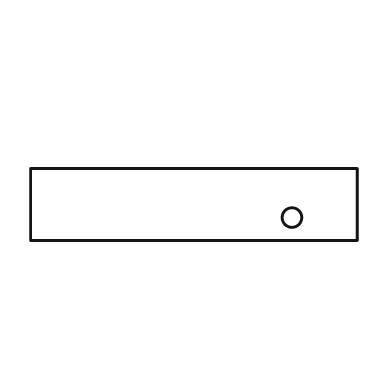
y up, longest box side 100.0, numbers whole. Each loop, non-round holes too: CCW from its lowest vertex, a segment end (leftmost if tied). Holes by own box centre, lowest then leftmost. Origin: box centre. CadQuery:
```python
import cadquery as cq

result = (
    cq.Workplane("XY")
    .moveTo(-50.0, -11.0)
    .lineTo(50.0, -11.0)
    .lineTo(50.0, 11.0)
    .lineTo(-50.0, 11.0)
    .close()
    .moveTo(30.0, -4.0)
    .circle(3.0)
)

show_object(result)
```